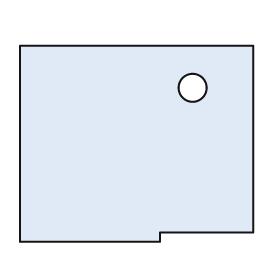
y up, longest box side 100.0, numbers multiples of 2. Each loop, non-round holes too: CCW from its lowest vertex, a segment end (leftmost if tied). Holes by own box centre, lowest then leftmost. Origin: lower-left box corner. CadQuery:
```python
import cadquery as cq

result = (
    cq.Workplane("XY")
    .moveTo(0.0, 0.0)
    .lineTo(60.0, 0.0)
    .lineTo(60.0, 4.0)
    .lineTo(100.0, 4.0)
    .lineTo(100.0, 84.0)
    .lineTo(0.0, 84.0)
    .close()
    .moveTo(74.0, 66.0)
    .circle(6.0)
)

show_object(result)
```